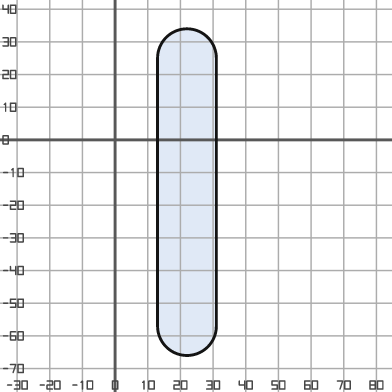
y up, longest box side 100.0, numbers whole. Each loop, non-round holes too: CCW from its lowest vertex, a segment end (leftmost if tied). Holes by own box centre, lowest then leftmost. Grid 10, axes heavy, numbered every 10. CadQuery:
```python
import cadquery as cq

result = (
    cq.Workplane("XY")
    .moveTo(13.0, -57.0)
    .threePointArc((22.0, -66.0), (31.0, -57.0))
    .lineTo(31.0, 25.0)
    .threePointArc((22.0, 34.0), (13.0, 25.0))
    .close()
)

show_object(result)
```